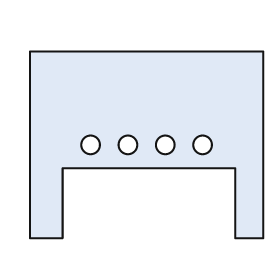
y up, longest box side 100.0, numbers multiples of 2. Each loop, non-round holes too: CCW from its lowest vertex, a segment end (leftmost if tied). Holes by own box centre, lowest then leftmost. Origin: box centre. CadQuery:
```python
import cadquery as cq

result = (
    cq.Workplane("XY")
    .moveTo(-50.0, -40.0)
    .lineTo(-36.0, -40.0)
    .lineTo(-36.0, -10.0)
    .lineTo(38.0, -10.0)
    .lineTo(38.0, -40.0)
    .lineTo(50.0, -40.0)
    .lineTo(50.0, 40.0)
    .lineTo(-50.0, 40.0)
    .close()
    .moveTo(-24.0, 0.0)
    .circle(4.0)
    .moveTo(-8.0, 0.0)
    .circle(4.0)
    .moveTo(8.0, 0.0)
    .circle(4.0)
    .moveTo(24.0, 0.0)
    .circle(4.0)
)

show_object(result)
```